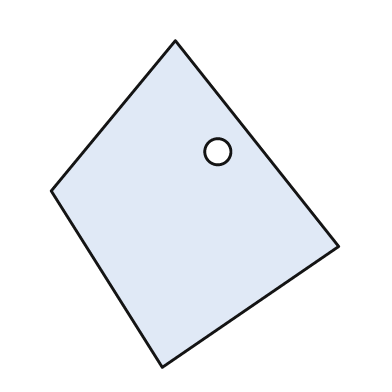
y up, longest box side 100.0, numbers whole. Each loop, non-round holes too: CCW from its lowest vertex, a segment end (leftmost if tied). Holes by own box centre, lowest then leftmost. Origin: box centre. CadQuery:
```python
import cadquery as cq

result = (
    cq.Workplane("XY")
    .moveTo(-10.0, -50.0)
    .lineTo(44.0, -13.0)
    .lineTo(-6.0, 50.0)
    .lineTo(-44.0, 4.0)
    .close()
    .moveTo(7.0, 16.0)
    .circle(4.0)
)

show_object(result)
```